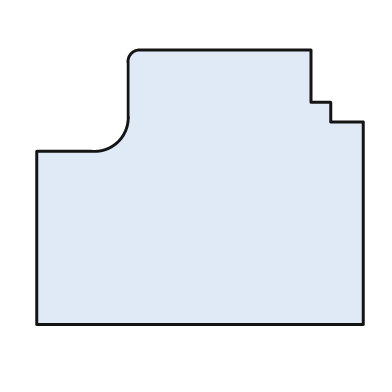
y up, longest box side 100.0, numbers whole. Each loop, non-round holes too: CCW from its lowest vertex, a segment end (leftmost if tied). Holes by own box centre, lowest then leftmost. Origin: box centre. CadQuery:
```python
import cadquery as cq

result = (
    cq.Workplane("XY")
    .moveTo(-50.0, -42.0)
    .lineTo(50.0, -42.0)
    .lineTo(50.0, 20.0)
    .lineTo(40.0, 20.0)
    .lineTo(40.0, 26.0)
    .lineTo(34.0, 26.0)
    .lineTo(34.0, 42.0)
    .lineTo(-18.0, 42.0)
    .threePointArc((-21.0, 41.0), (-22.0, 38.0))
    .lineTo(-22.0, 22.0)
    .threePointArc((-25.0, 14.0), (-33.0, 11.0))
    .lineTo(-50.0, 11.0)
    .close()
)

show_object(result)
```